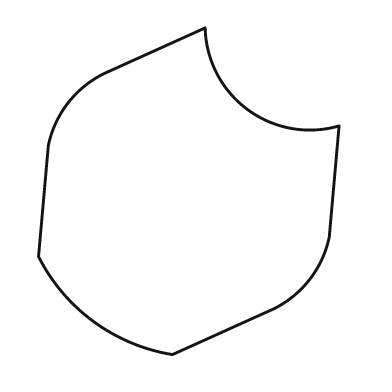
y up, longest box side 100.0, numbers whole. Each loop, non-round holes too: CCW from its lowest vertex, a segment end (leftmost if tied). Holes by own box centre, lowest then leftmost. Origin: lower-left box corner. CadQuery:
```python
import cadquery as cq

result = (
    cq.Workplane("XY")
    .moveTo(41.0, 0.0)
    .lineTo(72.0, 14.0)
    .threePointArc((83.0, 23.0), (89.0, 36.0))
    .lineTo(92.0, 70.0)
    .threePointArc((64.0, 75.0), (51.0, 100.0))
    .lineTo(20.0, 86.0)
    .threePointArc((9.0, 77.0), (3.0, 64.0))
    .lineTo(0.0, 30.0)
    .threePointArc((17.0, 10.0), (41.0, 0.0))
    .close()
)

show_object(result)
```